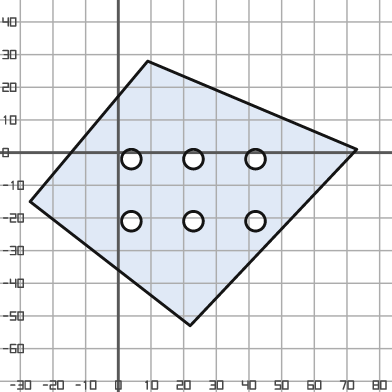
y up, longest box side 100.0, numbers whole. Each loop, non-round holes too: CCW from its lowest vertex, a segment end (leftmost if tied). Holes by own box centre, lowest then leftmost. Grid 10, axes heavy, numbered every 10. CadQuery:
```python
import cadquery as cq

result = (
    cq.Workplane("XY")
    .moveTo(22.0, -53.0)
    .lineTo(73.0, 1.0)
    .lineTo(9.0, 28.0)
    .lineTo(-27.0, -15.0)
    .close()
    .moveTo(4.0, -21.0)
    .circle(3.0)
    .moveTo(23.0, -21.0)
    .circle(3.0)
    .moveTo(42.0, -21.0)
    .circle(3.0)
    .moveTo(4.0, -2.0)
    .circle(3.0)
    .moveTo(23.0, -2.0)
    .circle(3.0)
    .moveTo(42.0, -2.0)
    .circle(3.0)
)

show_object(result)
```